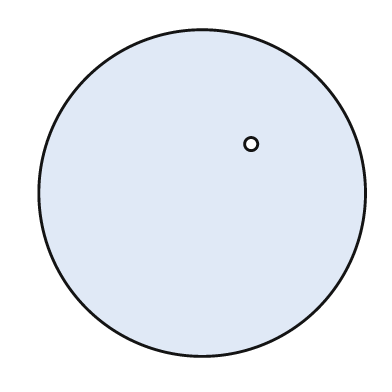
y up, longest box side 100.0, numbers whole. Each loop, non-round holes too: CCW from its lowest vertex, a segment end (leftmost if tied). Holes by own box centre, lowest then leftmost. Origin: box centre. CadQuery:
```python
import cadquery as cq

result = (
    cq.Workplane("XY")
    .moveTo(0.0, 0.0)
    .circle(50.0)
    .moveTo(15.0, 15.0)
    .circle(2.0)
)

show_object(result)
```